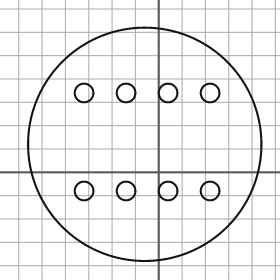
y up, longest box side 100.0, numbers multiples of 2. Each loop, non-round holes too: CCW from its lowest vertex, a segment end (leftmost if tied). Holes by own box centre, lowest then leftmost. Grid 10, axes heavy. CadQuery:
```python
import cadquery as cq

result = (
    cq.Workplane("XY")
    .moveTo(-6.0, 12.0)
    .circle(50.0)
    .moveTo(-32.0, -8.0)
    .circle(4.0)
    .moveTo(-14.0, -8.0)
    .circle(4.0)
    .moveTo(4.0, -8.0)
    .circle(4.0)
    .moveTo(22.0, -8.0)
    .circle(4.0)
    .moveTo(-32.0, 34.0)
    .circle(4.0)
    .moveTo(-14.0, 34.0)
    .circle(4.0)
    .moveTo(4.0, 34.0)
    .circle(4.0)
    .moveTo(22.0, 34.0)
    .circle(4.0)
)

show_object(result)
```